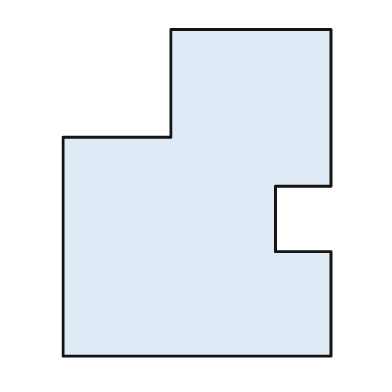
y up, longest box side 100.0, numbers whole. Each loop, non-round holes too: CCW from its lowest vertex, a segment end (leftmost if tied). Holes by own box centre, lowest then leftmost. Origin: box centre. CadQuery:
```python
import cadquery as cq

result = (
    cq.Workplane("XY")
    .moveTo(-41.0, -50.0)
    .lineTo(41.0, -50.0)
    .lineTo(41.0, -18.0)
    .lineTo(24.0, -18.0)
    .lineTo(24.0, 2.0)
    .lineTo(41.0, 2.0)
    .lineTo(41.0, 50.0)
    .lineTo(-8.0, 50.0)
    .lineTo(-8.0, 17.0)
    .lineTo(-41.0, 17.0)
    .close()
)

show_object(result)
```